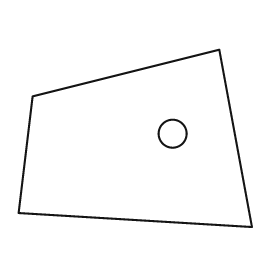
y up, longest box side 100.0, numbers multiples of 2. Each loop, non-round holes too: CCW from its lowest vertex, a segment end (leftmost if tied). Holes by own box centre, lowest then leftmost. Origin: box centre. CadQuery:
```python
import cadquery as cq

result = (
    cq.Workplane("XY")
    .moveTo(50.0, -38.0)
    .lineTo(36.0, 38.0)
    .lineTo(-44.0, 18.0)
    .lineTo(-50.0, -32.0)
    .close()
    .moveTo(16.0, 2.0)
    .circle(6.0)
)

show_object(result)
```